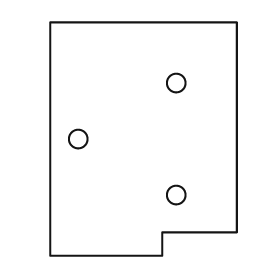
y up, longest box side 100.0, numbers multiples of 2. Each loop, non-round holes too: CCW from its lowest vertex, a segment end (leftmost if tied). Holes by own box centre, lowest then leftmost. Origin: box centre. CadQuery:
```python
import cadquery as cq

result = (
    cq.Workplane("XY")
    .moveTo(-40.0, -50.0)
    .lineTo(8.0, -50.0)
    .lineTo(8.0, -40.0)
    .lineTo(40.0, -40.0)
    .lineTo(40.0, 50.0)
    .lineTo(-40.0, 50.0)
    .close()
    .moveTo(14.0, -24.0)
    .circle(4.0)
    .moveTo(-28.0, 0.0)
    .circle(4.0)
    .moveTo(14.0, 24.0)
    .circle(4.0)
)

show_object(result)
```